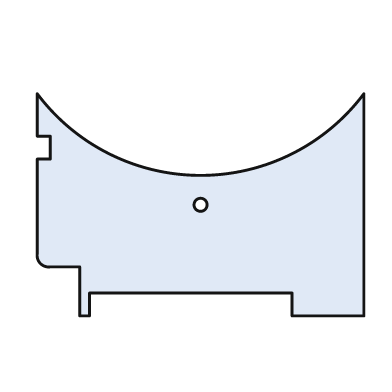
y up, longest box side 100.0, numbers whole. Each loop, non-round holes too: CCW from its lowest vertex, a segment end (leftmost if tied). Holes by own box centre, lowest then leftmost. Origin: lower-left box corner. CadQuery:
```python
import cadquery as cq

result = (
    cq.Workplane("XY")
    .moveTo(13.0, 0.0)
    .lineTo(16.0, 0.0)
    .lineTo(16.0, 7.0)
    .lineTo(78.0, 7.0)
    .lineTo(78.0, 0.0)
    .lineTo(100.0, 0.0)
    .lineTo(100.0, 68.0)
    .threePointArc((50.0, 43.0), (0.0, 68.0))
    .lineTo(0.0, 55.0)
    .lineTo(4.0, 55.0)
    .lineTo(4.0, 48.0)
    .lineTo(0.0, 48.0)
    .lineTo(0.0, 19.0)
    .threePointArc((1.0, 16.0), (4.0, 15.0))
    .lineTo(13.0, 15.0)
    .close()
    .moveTo(50.0, 34.0)
    .circle(2.0)
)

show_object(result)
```